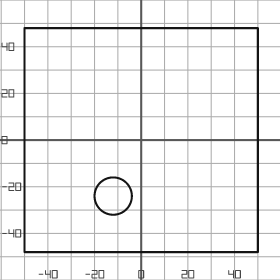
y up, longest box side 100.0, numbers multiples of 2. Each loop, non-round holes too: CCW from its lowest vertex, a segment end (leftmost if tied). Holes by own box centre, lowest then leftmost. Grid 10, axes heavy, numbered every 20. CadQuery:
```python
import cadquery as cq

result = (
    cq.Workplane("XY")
    .moveTo(-50.0, -48.0)
    .lineTo(50.0, -48.0)
    .lineTo(50.0, 48.0)
    .lineTo(-50.0, 48.0)
    .close()
    .moveTo(-12.0, -24.0)
    .circle(8.0)
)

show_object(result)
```